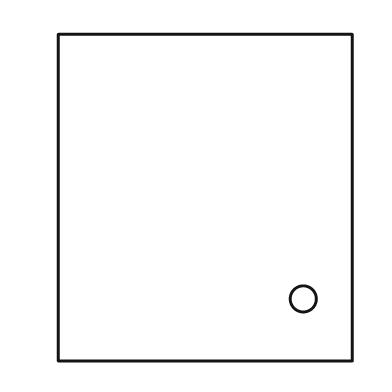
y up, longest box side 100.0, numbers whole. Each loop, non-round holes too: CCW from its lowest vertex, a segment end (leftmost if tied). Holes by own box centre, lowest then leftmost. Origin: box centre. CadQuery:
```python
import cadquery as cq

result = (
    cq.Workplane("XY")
    .moveTo(-45.0, -50.0)
    .lineTo(45.0, -50.0)
    .lineTo(45.0, 50.0)
    .lineTo(-45.0, 50.0)
    .close()
    .moveTo(30.0, -31.0)
    .circle(4.0)
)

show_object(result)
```